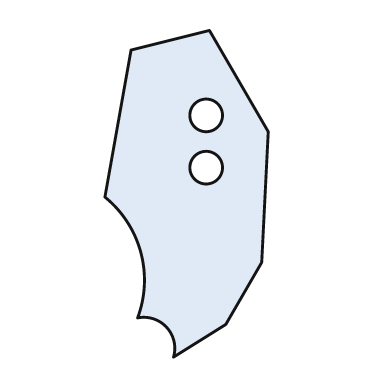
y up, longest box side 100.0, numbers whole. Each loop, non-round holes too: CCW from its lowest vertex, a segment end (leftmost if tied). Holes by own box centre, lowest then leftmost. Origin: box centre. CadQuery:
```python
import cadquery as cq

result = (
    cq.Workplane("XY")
    .moveTo(-4.0, -50.0)
    .lineTo(12.0, -40.0)
    .lineTo(23.0, -21.0)
    .lineTo(25.0, 19.0)
    .lineTo(7.0, 50.0)
    .lineTo(-17.0, 44.0)
    .lineTo(-25.0, -1.0)
    .threePointArc((-14.0, -18.0), (-15.0, -38.0))
    .threePointArc((-6.0, -41.0), (-4.0, -50.0))
    .close()
    .moveTo(6.0, 8.0)
    .circle(5.0)
    .moveTo(6.0, 24.0)
    .circle(5.0)
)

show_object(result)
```